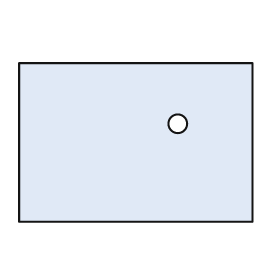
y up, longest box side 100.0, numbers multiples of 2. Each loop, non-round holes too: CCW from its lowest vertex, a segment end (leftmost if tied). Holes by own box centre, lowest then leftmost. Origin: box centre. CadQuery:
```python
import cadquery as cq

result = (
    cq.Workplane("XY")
    .moveTo(-50.0, -34.0)
    .lineTo(50.0, -34.0)
    .lineTo(50.0, 34.0)
    .lineTo(-50.0, 34.0)
    .close()
    .moveTo(18.0, 8.0)
    .circle(4.0)
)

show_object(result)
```